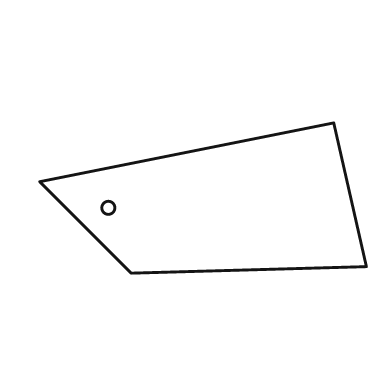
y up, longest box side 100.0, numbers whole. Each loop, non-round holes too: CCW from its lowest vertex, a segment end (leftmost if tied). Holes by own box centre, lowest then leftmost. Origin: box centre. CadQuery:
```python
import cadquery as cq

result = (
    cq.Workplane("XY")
    .moveTo(-22.0, -23.0)
    .lineTo(50.0, -21.0)
    .lineTo(40.0, 23.0)
    .lineTo(-50.0, 5.0)
    .close()
    .moveTo(-29.0, -3.0)
    .circle(2.0)
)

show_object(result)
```